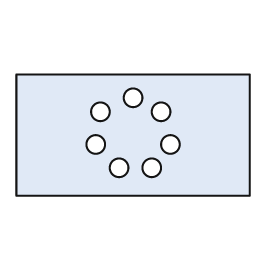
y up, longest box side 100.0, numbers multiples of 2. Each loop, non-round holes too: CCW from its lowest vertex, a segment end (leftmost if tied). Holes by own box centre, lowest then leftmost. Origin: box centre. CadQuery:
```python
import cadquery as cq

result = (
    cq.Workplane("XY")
    .moveTo(-50.0, -26.0)
    .lineTo(50.0, -26.0)
    .lineTo(50.0, 26.0)
    .lineTo(-50.0, 26.0)
    .close()
    .moveTo(-6.0, -14.0)
    .circle(4.0)
    .moveTo(8.0, -14.0)
    .circle(4.0)
    .moveTo(-16.0, -4.0)
    .circle(4.0)
    .moveTo(16.0, -4.0)
    .circle(4.0)
    .moveTo(-14.0, 10.0)
    .circle(4.0)
    .moveTo(12.0, 10.0)
    .circle(4.0)
    .moveTo(0.0, 16.0)
    .circle(4.0)
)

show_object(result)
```